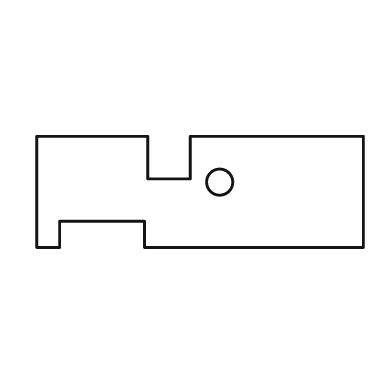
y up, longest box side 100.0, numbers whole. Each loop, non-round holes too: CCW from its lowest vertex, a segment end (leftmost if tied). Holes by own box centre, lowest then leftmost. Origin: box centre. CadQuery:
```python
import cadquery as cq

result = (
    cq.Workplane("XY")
    .moveTo(-50.0, -17.0)
    .lineTo(-43.0, -17.0)
    .lineTo(-43.0, -9.0)
    .lineTo(-17.0, -9.0)
    .lineTo(-17.0, -17.0)
    .lineTo(50.0, -17.0)
    .lineTo(50.0, 17.0)
    .lineTo(-3.0, 17.0)
    .lineTo(-3.0, 4.0)
    .lineTo(-16.0, 4.0)
    .lineTo(-16.0, 17.0)
    .lineTo(-50.0, 17.0)
    .close()
    .moveTo(6.0, 3.0)
    .circle(4.0)
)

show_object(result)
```